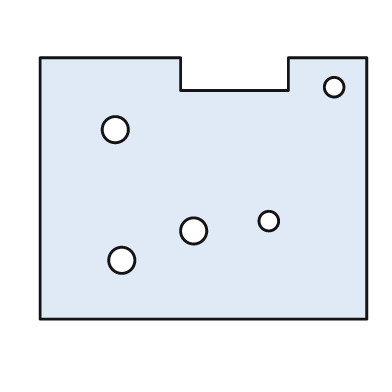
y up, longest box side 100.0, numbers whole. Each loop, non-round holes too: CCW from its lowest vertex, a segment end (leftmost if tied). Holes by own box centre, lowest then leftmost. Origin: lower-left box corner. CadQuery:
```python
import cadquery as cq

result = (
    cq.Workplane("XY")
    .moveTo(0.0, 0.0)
    .lineTo(100.0, 0.0)
    .lineTo(100.0, 80.0)
    .lineTo(76.0, 80.0)
    .lineTo(76.0, 70.0)
    .lineTo(43.0, 70.0)
    .lineTo(43.0, 80.0)
    .lineTo(0.0, 80.0)
    .close()
    .moveTo(25.0, 18.0)
    .circle(4.0)
    .moveTo(47.0, 27.0)
    .circle(4.0)
    .moveTo(70.0, 30.0)
    .circle(3.0)
    .moveTo(23.0, 58.0)
    .circle(4.0)
    .moveTo(90.0, 71.0)
    .circle(3.0)
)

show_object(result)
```